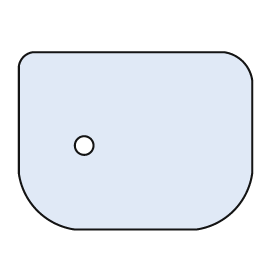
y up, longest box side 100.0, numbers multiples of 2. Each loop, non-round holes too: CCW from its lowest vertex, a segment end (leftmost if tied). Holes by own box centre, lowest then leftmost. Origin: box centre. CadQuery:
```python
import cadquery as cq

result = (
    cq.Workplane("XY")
    .moveTo(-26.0, -38.0)
    .lineTo(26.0, -38.0)
    .threePointArc((42.0, -30.0), (50.0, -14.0))
    .lineTo(50.0, 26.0)
    .threePointArc((46.0, 34.0), (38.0, 38.0))
    .lineTo(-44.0, 38.0)
    .threePointArc((-48.0, 36.0), (-50.0, 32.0))
    .lineTo(-50.0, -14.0)
    .threePointArc((-42.0, -30.0), (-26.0, -38.0))
    .close()
    .moveTo(-22.0, -2.0)
    .circle(4.0)
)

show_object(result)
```